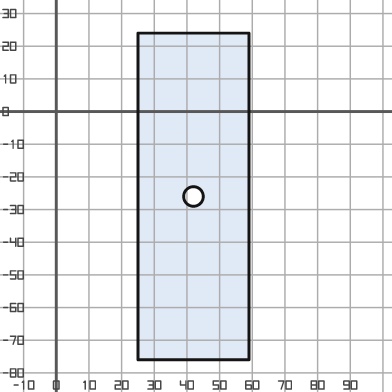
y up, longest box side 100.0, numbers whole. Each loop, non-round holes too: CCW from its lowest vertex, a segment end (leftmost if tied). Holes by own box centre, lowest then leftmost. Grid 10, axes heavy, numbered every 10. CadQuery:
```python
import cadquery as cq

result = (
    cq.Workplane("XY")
    .moveTo(25.0, -76.0)
    .lineTo(59.0, -76.0)
    .lineTo(59.0, 24.0)
    .lineTo(25.0, 24.0)
    .close()
    .moveTo(42.0, -26.0)
    .circle(3.0)
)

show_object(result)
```